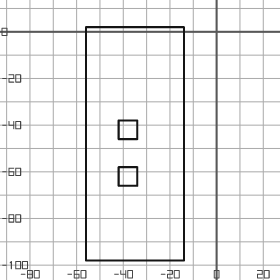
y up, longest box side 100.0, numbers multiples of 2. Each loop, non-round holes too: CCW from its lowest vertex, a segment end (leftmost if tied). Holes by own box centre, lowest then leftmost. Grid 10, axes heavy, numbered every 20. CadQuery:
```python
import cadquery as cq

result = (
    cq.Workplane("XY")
    .moveTo(-56.0, -98.0)
    .lineTo(-14.0, -98.0)
    .lineTo(-14.0, 2.0)
    .lineTo(-56.0, 2.0)
    .close()
    .moveTo(-42.0, -66.0)
    .lineTo(-34.0, -66.0)
    .lineTo(-34.0, -58.0)
    .lineTo(-42.0, -58.0)
    .close()
    .moveTo(-42.0, -46.0)
    .lineTo(-34.0, -46.0)
    .lineTo(-34.0, -38.0)
    .lineTo(-42.0, -38.0)
    .close()
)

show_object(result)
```